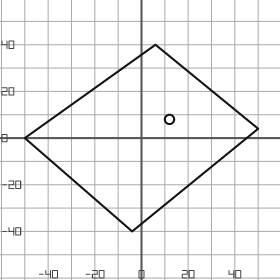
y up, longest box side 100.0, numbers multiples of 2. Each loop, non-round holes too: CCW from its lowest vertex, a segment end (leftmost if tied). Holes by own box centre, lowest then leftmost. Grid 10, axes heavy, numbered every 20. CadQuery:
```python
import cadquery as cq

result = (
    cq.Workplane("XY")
    .moveTo(-4.0, -40.0)
    .lineTo(50.0, 4.0)
    .lineTo(6.0, 40.0)
    .lineTo(-50.0, 0.0)
    .close()
    .moveTo(12.0, 8.0)
    .circle(2.0)
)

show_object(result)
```